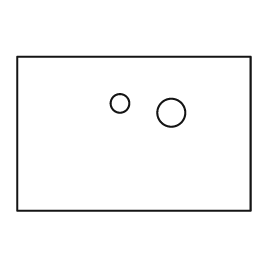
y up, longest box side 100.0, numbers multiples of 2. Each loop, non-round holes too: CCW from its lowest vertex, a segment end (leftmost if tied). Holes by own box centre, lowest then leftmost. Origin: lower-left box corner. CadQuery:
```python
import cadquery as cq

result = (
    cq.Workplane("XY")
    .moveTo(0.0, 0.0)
    .lineTo(100.0, 0.0)
    .lineTo(100.0, 66.0)
    .lineTo(0.0, 66.0)
    .close()
    .moveTo(66.0, 42.0)
    .circle(6.0)
    .moveTo(44.0, 46.0)
    .circle(4.0)
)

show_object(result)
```